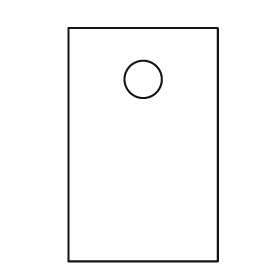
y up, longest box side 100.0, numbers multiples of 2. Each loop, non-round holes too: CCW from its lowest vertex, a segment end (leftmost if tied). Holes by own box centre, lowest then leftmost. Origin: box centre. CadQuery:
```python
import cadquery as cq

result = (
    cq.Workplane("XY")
    .moveTo(-32.0, -50.0)
    .lineTo(32.0, -50.0)
    .lineTo(32.0, 50.0)
    .lineTo(-32.0, 50.0)
    .close()
    .moveTo(0.0, 28.0)
    .circle(8.0)
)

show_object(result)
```